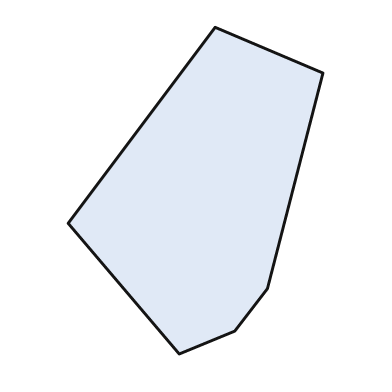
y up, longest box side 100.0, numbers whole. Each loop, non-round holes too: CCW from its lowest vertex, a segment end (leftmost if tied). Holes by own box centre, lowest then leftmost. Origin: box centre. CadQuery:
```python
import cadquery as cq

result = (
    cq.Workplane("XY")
    .moveTo(-5.0, -50.0)
    .lineTo(12.0, -43.0)
    .lineTo(22.0, -30.0)
    .lineTo(39.0, 36.0)
    .lineTo(6.0, 50.0)
    .lineTo(-39.0, -10.0)
    .close()
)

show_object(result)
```